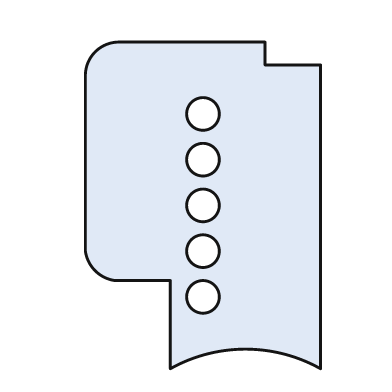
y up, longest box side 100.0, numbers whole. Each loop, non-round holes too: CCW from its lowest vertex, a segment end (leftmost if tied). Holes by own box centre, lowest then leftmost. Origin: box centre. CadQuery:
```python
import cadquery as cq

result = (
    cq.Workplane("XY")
    .moveTo(-10.0, -50.0)
    .threePointArc((13.0, -44.0), (36.0, -50.0))
    .lineTo(36.0, 43.0)
    .lineTo(19.0, 43.0)
    .lineTo(19.0, 50.0)
    .lineTo(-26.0, 50.0)
    .threePointArc((-33.0, 47.0), (-36.0, 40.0))
    .lineTo(-36.0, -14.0)
    .threePointArc((-33.0, -20.0), (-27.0, -23.0))
    .lineTo(-10.0, -23.0)
    .close()
    .moveTo(0.0, -28.0)
    .circle(5.0)
    .moveTo(0.0, -14.0)
    .circle(5.0)
    .moveTo(0.0, 0.0)
    .circle(5.0)
    .moveTo(0.0, 14.0)
    .circle(5.0)
    .moveTo(0.0, 28.0)
    .circle(5.0)
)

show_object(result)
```